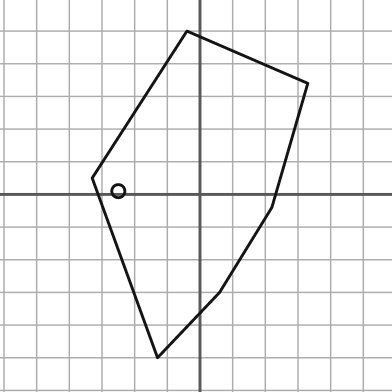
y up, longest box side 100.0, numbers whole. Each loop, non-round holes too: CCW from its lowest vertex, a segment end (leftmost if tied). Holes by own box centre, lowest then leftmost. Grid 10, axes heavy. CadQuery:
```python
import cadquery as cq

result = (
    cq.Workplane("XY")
    .moveTo(-13.0, -50.0)
    .lineTo(6.0, -30.0)
    .lineTo(22.0, -4.0)
    .lineTo(33.0, 34.0)
    .lineTo(-4.0, 50.0)
    .lineTo(-33.0, 5.0)
    .close()
    .moveTo(-25.0, 1.0)
    .circle(2.0)
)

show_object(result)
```